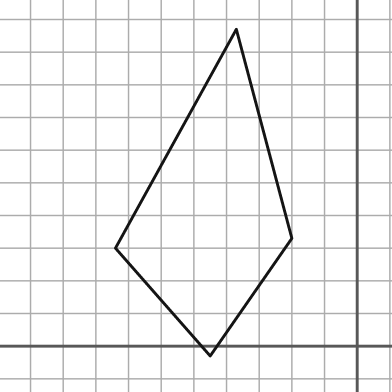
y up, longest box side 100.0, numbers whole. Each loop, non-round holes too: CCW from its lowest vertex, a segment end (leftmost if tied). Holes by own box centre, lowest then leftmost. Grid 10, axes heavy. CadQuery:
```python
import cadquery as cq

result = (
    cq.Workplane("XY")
    .moveTo(-45.0, -3.0)
    .lineTo(-20.0, 33.0)
    .lineTo(-37.0, 97.0)
    .lineTo(-74.0, 30.0)
    .close()
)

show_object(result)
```